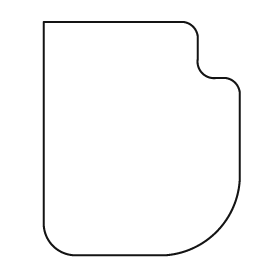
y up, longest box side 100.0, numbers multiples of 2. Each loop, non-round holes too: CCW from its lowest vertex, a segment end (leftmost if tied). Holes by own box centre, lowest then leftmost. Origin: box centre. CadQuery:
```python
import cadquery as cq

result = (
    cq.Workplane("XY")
    .moveTo(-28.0, -50.0)
    .lineTo(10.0, -50.0)
    .threePointArc((32.0, -40.0), (42.0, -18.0))
    .lineTo(42.0, 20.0)
    .threePointArc((40.0, 24.0), (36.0, 26.0))
    .lineTo(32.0, 26.0)
    .threePointArc((26.0, 28.0), (24.0, 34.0))
    .lineTo(24.0, 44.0)
    .threePointArc((22.0, 48.0), (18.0, 50.0))
    .lineTo(-42.0, 50.0)
    .lineTo(-42.0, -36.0)
    .threePointArc((-38.0, -46.0), (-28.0, -50.0))
    .close()
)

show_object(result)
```